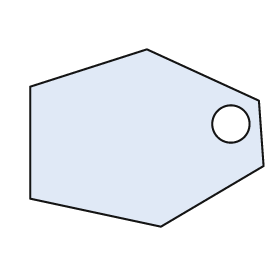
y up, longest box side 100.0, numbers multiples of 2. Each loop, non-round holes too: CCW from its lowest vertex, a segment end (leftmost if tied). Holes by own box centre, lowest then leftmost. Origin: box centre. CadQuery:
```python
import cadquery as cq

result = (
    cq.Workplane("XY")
    .moveTo(6.0, -38.0)
    .lineTo(50.0, -12.0)
    .lineTo(48.0, 16.0)
    .lineTo(0.0, 38.0)
    .lineTo(-50.0, 22.0)
    .lineTo(-50.0, -26.0)
    .close()
    .moveTo(36.0, 6.0)
    .circle(8.0)
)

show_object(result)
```